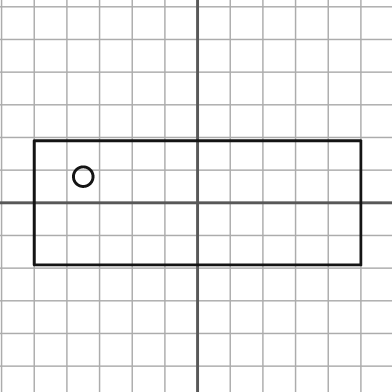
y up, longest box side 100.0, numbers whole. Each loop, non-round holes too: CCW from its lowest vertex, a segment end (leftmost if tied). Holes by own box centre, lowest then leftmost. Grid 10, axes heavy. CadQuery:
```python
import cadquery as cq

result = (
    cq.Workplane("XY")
    .moveTo(-50.0, -19.0)
    .lineTo(50.0, -19.0)
    .lineTo(50.0, 19.0)
    .lineTo(-50.0, 19.0)
    .close()
    .moveTo(-35.0, 8.0)
    .circle(3.0)
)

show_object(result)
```